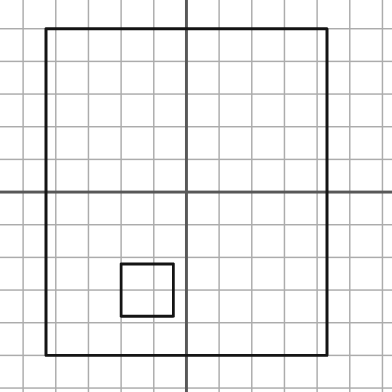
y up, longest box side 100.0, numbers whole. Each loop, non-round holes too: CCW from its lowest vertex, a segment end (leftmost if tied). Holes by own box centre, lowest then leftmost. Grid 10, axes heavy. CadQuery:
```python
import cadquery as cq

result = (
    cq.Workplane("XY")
    .moveTo(-43.0, -50.0)
    .lineTo(43.0, -50.0)
    .lineTo(43.0, 50.0)
    .lineTo(-43.0, 50.0)
    .close()
    .moveTo(-20.0, -38.0)
    .lineTo(-4.0, -38.0)
    .lineTo(-4.0, -22.0)
    .lineTo(-20.0, -22.0)
    .close()
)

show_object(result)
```